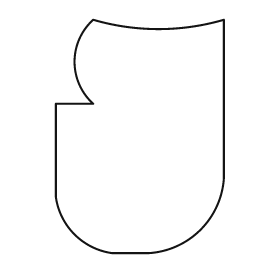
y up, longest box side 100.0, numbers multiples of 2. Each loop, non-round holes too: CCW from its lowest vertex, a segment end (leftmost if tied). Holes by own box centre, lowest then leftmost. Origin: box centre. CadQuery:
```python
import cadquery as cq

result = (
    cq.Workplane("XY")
    .moveTo(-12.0, -50.0)
    .lineTo(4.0, -50.0)
    .threePointArc((26.0, -40.0), (36.0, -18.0))
    .lineTo(36.0, 50.0)
    .threePointArc((8.0, 46.0), (-20.0, 50.0))
    .threePointArc((-28.0, 32.0), (-20.0, 14.0))
    .lineTo(-36.0, 14.0)
    .lineTo(-36.0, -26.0)
    .threePointArc((-28.0, -42.0), (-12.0, -50.0))
    .close()
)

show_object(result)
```